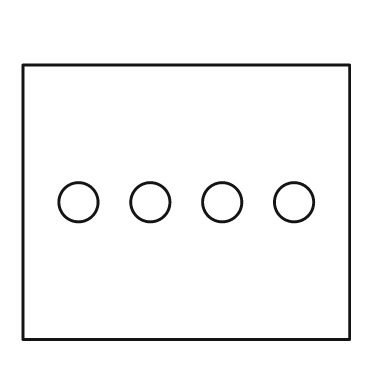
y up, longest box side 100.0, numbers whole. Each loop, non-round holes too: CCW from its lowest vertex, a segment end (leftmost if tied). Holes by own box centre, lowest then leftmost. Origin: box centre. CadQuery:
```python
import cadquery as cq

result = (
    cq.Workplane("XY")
    .moveTo(-50.0, -42.0)
    .lineTo(50.0, -42.0)
    .lineTo(50.0, 42.0)
    .lineTo(-50.0, 42.0)
    .close()
    .moveTo(-33.0, 0.0)
    .circle(6.0)
    .moveTo(-11.0, 0.0)
    .circle(6.0)
    .moveTo(11.0, 0.0)
    .circle(6.0)
    .moveTo(33.0, 0.0)
    .circle(6.0)
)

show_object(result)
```